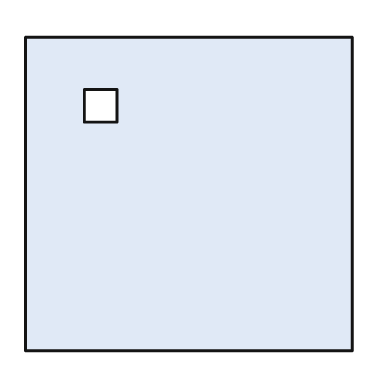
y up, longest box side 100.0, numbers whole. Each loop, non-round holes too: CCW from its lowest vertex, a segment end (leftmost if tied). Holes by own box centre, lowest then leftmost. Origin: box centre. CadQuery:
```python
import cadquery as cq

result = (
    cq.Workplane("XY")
    .moveTo(-50.0, -48.0)
    .lineTo(50.0, -48.0)
    .lineTo(50.0, 48.0)
    .lineTo(-50.0, 48.0)
    .close()
    .moveTo(-32.0, 22.0)
    .lineTo(-22.0, 22.0)
    .lineTo(-22.0, 32.0)
    .lineTo(-32.0, 32.0)
    .close()
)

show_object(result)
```